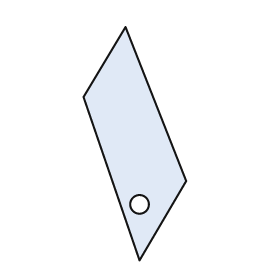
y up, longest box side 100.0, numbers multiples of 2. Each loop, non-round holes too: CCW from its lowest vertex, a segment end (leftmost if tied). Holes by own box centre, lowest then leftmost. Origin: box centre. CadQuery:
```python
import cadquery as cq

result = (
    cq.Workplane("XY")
    .moveTo(2.0, -50.0)
    .lineTo(22.0, -16.0)
    .lineTo(-4.0, 50.0)
    .lineTo(-22.0, 20.0)
    .close()
    .moveTo(2.0, -26.0)
    .circle(4.0)
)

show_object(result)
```